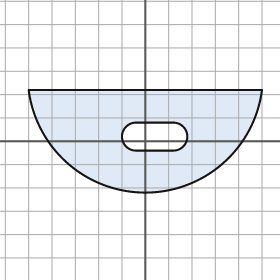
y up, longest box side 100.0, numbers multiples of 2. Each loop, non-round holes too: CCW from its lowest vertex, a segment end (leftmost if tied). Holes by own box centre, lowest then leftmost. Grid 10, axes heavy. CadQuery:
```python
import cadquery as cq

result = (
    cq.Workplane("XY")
    .moveTo(-50.0, 22.0)
    .threePointArc((0.0, -22.0), (50.0, 22.0))
    .close()
    .moveTo(-4.0, -4.0)
    .lineTo(12.0, -4.0)
    .threePointArc((18.0, 2.0), (12.0, 8.0))
    .lineTo(-4.0, 8.0)
    .threePointArc((-10.0, 2.0), (-4.0, -4.0))
    .close()
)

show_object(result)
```